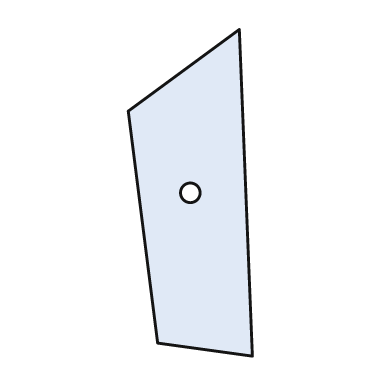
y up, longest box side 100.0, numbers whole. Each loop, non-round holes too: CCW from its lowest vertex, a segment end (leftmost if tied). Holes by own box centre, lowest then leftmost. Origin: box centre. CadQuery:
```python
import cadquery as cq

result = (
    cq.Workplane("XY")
    .moveTo(19.0, -50.0)
    .lineTo(15.0, 50.0)
    .lineTo(-19.0, 25.0)
    .lineTo(-10.0, -46.0)
    .close()
    .moveTo(0.0, 0.0)
    .circle(3.0)
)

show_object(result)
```